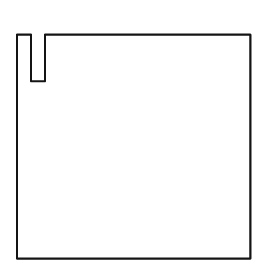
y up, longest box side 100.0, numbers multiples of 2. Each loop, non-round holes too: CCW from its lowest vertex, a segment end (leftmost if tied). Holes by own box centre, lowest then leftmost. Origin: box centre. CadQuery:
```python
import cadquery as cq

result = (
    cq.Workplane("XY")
    .moveTo(-50.0, -48.0)
    .lineTo(50.0, -48.0)
    .lineTo(50.0, 48.0)
    .lineTo(-38.0, 48.0)
    .lineTo(-38.0, 28.0)
    .lineTo(-44.0, 28.0)
    .lineTo(-44.0, 48.0)
    .lineTo(-50.0, 48.0)
    .close()
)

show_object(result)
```